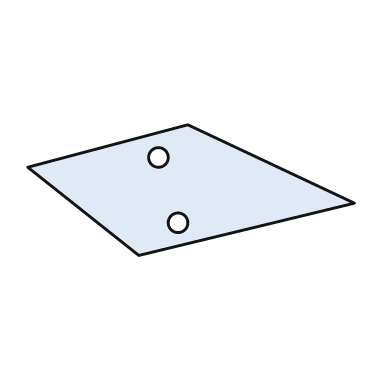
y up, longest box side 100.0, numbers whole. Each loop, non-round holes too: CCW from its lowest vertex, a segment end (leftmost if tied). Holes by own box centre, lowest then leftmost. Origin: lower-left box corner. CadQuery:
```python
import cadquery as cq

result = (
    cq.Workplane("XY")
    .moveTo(34.0, 0.0)
    .lineTo(100.0, 16.0)
    .lineTo(49.0, 40.0)
    .lineTo(0.0, 27.0)
    .close()
    .moveTo(46.0, 10.0)
    .circle(3.0)
    .moveTo(40.0, 30.0)
    .circle(3.0)
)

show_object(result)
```